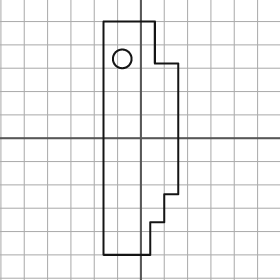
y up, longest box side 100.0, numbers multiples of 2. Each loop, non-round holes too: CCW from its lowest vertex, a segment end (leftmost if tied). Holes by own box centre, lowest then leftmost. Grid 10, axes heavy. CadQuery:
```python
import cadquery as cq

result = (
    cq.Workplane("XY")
    .moveTo(-16.0, -50.0)
    .lineTo(4.0, -50.0)
    .lineTo(4.0, -36.0)
    .lineTo(10.0, -36.0)
    .lineTo(10.0, -24.0)
    .lineTo(16.0, -24.0)
    .lineTo(16.0, 32.0)
    .lineTo(6.0, 32.0)
    .lineTo(6.0, 50.0)
    .lineTo(-16.0, 50.0)
    .close()
    .moveTo(-8.0, 34.0)
    .circle(4.0)
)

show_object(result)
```